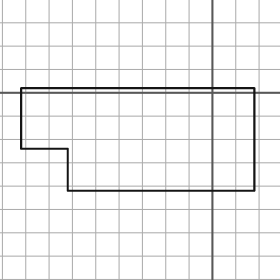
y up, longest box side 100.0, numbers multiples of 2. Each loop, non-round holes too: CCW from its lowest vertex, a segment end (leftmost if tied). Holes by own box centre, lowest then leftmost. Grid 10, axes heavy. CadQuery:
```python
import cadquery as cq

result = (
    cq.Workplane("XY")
    .moveTo(-62.0, -42.0)
    .lineTo(18.0, -42.0)
    .lineTo(18.0, 2.0)
    .lineTo(-82.0, 2.0)
    .lineTo(-82.0, -24.0)
    .lineTo(-62.0, -24.0)
    .close()
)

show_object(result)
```